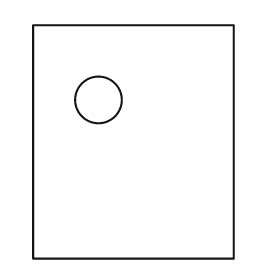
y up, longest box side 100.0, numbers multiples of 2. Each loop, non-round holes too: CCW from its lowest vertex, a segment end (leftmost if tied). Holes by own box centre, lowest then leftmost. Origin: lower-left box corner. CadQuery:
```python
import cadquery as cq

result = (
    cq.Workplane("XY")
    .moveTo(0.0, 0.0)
    .lineTo(86.0, 0.0)
    .lineTo(86.0, 100.0)
    .lineTo(0.0, 100.0)
    .close()
    .moveTo(28.0, 68.0)
    .circle(10.0)
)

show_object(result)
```